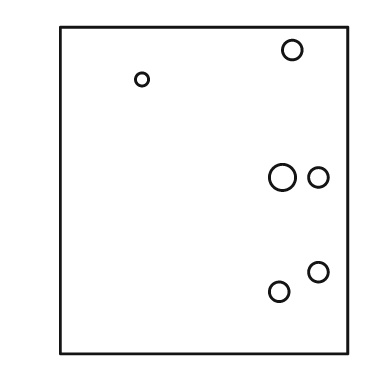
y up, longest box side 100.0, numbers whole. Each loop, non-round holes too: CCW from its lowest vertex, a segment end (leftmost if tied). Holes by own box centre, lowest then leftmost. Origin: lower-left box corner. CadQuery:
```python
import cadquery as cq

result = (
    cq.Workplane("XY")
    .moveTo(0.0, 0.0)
    .lineTo(88.0, 0.0)
    .lineTo(88.0, 100.0)
    .lineTo(0.0, 100.0)
    .close()
    .moveTo(67.0, 19.0)
    .circle(3.0)
    .moveTo(79.0, 25.0)
    .circle(3.0)
    .moveTo(68.0, 54.0)
    .circle(4.0)
    .moveTo(79.0, 54.0)
    .circle(3.0)
    .moveTo(25.0, 84.0)
    .circle(2.0)
    .moveTo(71.0, 93.0)
    .circle(3.0)
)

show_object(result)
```